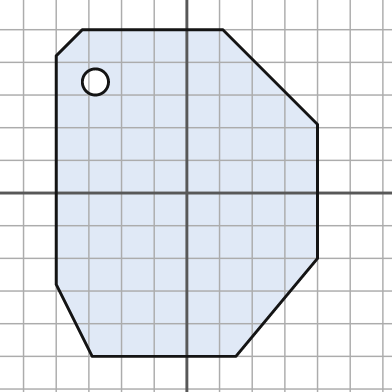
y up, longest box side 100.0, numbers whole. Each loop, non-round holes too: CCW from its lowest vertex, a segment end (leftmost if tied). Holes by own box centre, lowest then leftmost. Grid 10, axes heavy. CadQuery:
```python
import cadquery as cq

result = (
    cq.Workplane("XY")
    .moveTo(-29.0, -50.0)
    .lineTo(15.0, -50.0)
    .lineTo(40.0, -20.0)
    .lineTo(40.0, 21.0)
    .lineTo(11.0, 50.0)
    .lineTo(-32.0, 50.0)
    .lineTo(-40.0, 42.0)
    .lineTo(-40.0, -28.0)
    .close()
    .moveTo(-28.0, 34.0)
    .circle(4.0)
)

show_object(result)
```